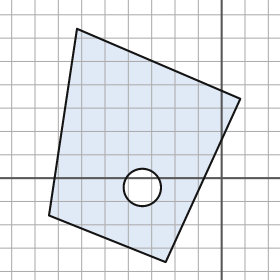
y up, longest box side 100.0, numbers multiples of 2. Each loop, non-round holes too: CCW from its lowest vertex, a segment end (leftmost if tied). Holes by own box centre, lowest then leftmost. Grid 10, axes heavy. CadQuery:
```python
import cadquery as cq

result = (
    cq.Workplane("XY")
    .moveTo(-24.0, -36.0)
    .lineTo(8.0, 34.0)
    .lineTo(-62.0, 64.0)
    .lineTo(-74.0, -16.0)
    .close()
    .moveTo(-34.0, -4.0)
    .circle(8.0)
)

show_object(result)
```